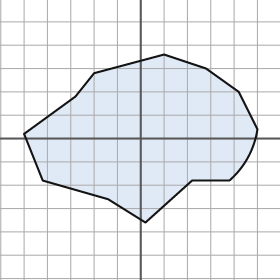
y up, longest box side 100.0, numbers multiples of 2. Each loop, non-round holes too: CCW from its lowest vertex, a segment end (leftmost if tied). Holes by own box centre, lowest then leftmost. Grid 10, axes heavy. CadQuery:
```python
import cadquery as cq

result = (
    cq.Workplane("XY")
    .moveTo(2.0, -36.0)
    .lineTo(22.0, -18.0)
    .lineTo(38.0, -18.0)
    .threePointArc((46.0, -8.0), (50.0, 4.0))
    .lineTo(42.0, 20.0)
    .lineTo(28.0, 30.0)
    .lineTo(10.0, 36.0)
    .lineTo(-20.0, 28.0)
    .lineTo(-28.0, 18.0)
    .lineTo(-50.0, 2.0)
    .lineTo(-42.0, -18.0)
    .lineTo(-14.0, -26.0)
    .close()
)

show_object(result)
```